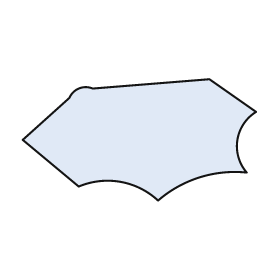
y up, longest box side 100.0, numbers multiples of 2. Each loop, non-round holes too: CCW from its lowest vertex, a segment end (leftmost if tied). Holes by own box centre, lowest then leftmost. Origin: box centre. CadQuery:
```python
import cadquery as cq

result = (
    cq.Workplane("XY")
    .moveTo(8.0, -26.0)
    .threePointArc((26.0, -16.0), (46.0, -14.0))
    .threePointArc((42.0, 0.0), (50.0, 12.0))
    .lineTo(30.0, 26.0)
    .lineTo(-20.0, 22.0)
    .threePointArc((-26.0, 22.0), (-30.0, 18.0))
    .lineTo(-50.0, 0.0)
    .lineTo(-26.0, -20.0)
    .threePointArc((-8.0, -18.0), (8.0, -26.0))
    .close()
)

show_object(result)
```